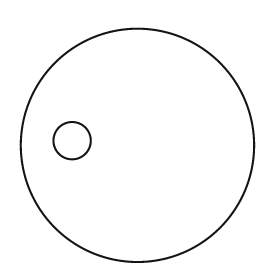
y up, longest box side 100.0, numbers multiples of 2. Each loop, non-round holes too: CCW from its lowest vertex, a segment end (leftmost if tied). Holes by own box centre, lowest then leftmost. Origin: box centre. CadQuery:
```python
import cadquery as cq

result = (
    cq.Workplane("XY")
    .moveTo(0.0, 0.0)
    .circle(50.0)
    .moveTo(-28.0, 2.0)
    .circle(8.0)
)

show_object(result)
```